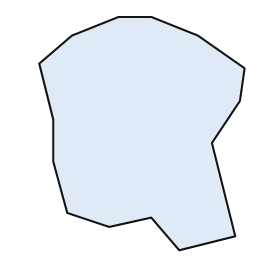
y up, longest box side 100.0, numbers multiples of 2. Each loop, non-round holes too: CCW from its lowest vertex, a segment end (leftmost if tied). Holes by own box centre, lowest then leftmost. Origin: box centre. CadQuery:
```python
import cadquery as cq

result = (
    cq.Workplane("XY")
    .moveTo(16.0, -50.0)
    .lineTo(40.0, -44.0)
    .lineTo(30.0, -4.0)
    .lineTo(42.0, 14.0)
    .lineTo(44.0, 28.0)
    .lineTo(24.0, 42.0)
    .lineTo(4.0, 50.0)
    .lineTo(-10.0, 50.0)
    .lineTo(-30.0, 42.0)
    .lineTo(-44.0, 30.0)
    .lineTo(-38.0, 6.0)
    .lineTo(-38.0, -12.0)
    .lineTo(-32.0, -34.0)
    .lineTo(-14.0, -40.0)
    .lineTo(4.0, -36.0)
    .close()
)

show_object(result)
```